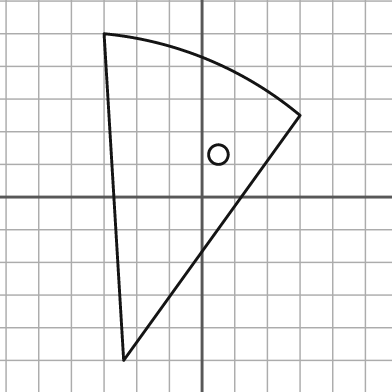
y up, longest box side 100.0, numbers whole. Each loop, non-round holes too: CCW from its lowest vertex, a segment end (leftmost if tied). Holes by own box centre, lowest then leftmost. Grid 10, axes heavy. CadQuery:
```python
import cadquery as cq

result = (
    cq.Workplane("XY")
    .moveTo(-24.0, -50.0)
    .lineTo(30.0, 25.0)
    .threePointArc((2.0, 42.0), (-30.0, 50.0))
    .close()
    .moveTo(5.0, 13.0)
    .circle(3.0)
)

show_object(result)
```